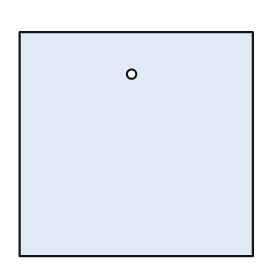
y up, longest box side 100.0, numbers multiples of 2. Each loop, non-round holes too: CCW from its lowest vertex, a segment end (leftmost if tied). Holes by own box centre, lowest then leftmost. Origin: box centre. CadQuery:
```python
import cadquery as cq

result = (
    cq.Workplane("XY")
    .moveTo(-50.0, -48.0)
    .lineTo(50.0, -48.0)
    .lineTo(50.0, 48.0)
    .lineTo(-50.0, 48.0)
    .close()
    .moveTo(-2.0, 30.0)
    .circle(2.0)
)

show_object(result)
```